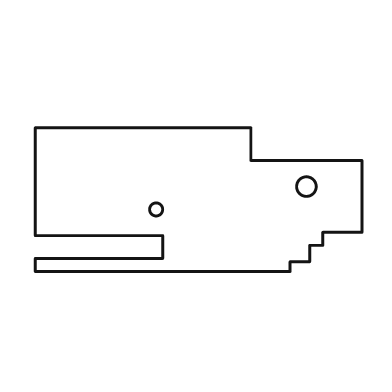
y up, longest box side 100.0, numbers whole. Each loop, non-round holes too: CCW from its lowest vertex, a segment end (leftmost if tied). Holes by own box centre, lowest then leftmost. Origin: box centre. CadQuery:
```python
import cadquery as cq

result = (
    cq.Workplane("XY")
    .moveTo(-50.0, -22.0)
    .lineTo(28.0, -22.0)
    .lineTo(28.0, -19.0)
    .lineTo(34.0, -19.0)
    .lineTo(34.0, -14.0)
    .lineTo(38.0, -14.0)
    .lineTo(38.0, -10.0)
    .lineTo(50.0, -10.0)
    .lineTo(50.0, 12.0)
    .lineTo(16.0, 12.0)
    .lineTo(16.0, 22.0)
    .lineTo(-50.0, 22.0)
    .lineTo(-50.0, -11.0)
    .lineTo(-11.0, -11.0)
    .lineTo(-11.0, -18.0)
    .lineTo(-50.0, -18.0)
    .close()
    .moveTo(-13.0, -3.0)
    .circle(2.0)
    .moveTo(33.0, 4.0)
    .circle(3.0)
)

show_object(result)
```